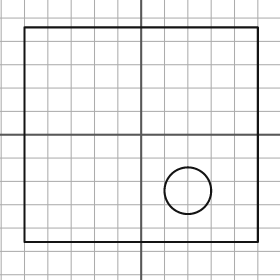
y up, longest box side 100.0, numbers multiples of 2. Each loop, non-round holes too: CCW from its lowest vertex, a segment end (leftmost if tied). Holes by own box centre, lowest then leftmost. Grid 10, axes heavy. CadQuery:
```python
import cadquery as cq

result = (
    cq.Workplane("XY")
    .moveTo(-50.0, -46.0)
    .lineTo(50.0, -46.0)
    .lineTo(50.0, 46.0)
    .lineTo(-50.0, 46.0)
    .close()
    .moveTo(20.0, -24.0)
    .circle(10.0)
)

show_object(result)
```